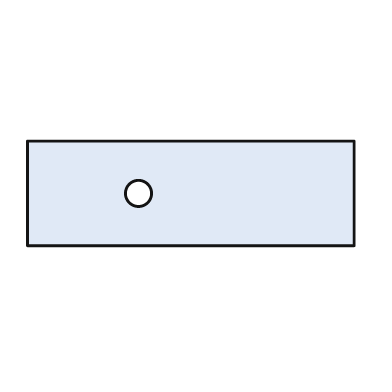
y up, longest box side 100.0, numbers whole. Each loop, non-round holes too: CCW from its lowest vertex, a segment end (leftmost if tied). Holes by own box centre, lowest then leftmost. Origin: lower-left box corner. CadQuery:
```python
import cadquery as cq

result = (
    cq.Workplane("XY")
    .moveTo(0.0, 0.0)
    .lineTo(100.0, 0.0)
    .lineTo(100.0, 32.0)
    .lineTo(0.0, 32.0)
    .close()
    .moveTo(34.0, 16.0)
    .circle(4.0)
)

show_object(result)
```